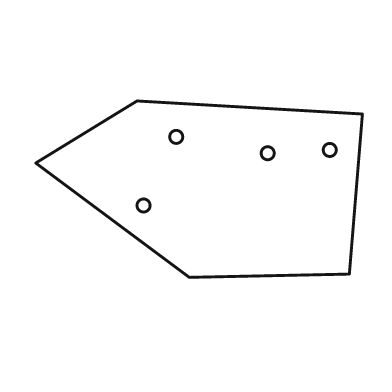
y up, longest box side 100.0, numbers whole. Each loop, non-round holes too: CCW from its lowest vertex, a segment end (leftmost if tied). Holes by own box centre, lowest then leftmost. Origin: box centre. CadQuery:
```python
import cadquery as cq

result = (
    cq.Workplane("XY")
    .moveTo(-3.0, -27.0)
    .lineTo(46.0, -26.0)
    .lineTo(50.0, 23.0)
    .lineTo(-19.0, 27.0)
    .lineTo(-50.0, 8.0)
    .close()
    .moveTo(-17.0, -5.0)
    .circle(2.0)
    .moveTo(21.0, 11.0)
    .circle(2.0)
    .moveTo(40.0, 12.0)
    .circle(2.0)
    .moveTo(-7.0, 16.0)
    .circle(2.0)
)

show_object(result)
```